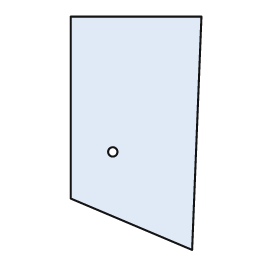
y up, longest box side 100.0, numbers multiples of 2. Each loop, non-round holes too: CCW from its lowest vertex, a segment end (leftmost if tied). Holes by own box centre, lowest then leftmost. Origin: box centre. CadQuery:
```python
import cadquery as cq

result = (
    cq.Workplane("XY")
    .moveTo(24.0, -50.0)
    .lineTo(28.0, 50.0)
    .lineTo(-28.0, 50.0)
    .lineTo(-28.0, -28.0)
    .close()
    .moveTo(-10.0, -8.0)
    .circle(2.0)
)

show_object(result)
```